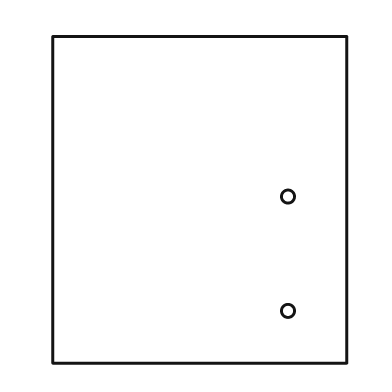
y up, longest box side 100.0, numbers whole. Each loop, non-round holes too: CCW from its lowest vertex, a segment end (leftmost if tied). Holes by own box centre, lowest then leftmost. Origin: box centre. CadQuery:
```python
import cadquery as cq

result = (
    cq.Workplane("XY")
    .moveTo(-45.0, -50.0)
    .lineTo(45.0, -50.0)
    .lineTo(45.0, 50.0)
    .lineTo(-45.0, 50.0)
    .close()
    .moveTo(27.0, -34.0)
    .circle(2.0)
    .moveTo(27.0, 1.0)
    .circle(2.0)
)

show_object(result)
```